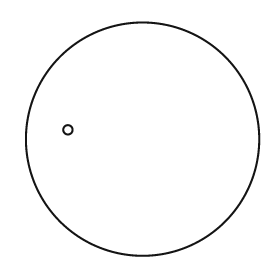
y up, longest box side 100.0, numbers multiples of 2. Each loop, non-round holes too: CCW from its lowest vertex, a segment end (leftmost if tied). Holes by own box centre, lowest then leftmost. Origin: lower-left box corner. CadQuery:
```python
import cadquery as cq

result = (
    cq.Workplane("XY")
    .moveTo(50.0, 50.0)
    .circle(50.0)
    .moveTo(18.0, 54.0)
    .circle(2.0)
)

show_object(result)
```